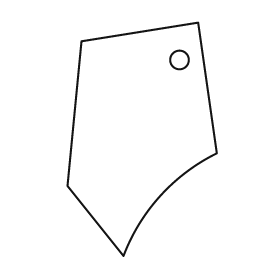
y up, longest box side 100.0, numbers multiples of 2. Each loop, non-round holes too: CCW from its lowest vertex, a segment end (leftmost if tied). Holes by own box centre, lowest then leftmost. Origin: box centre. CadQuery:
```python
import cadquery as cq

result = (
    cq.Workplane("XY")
    .moveTo(-8.0, -50.0)
    .threePointArc((8.0, -24.0), (32.0, -6.0))
    .lineTo(24.0, 50.0)
    .lineTo(-26.0, 42.0)
    .lineTo(-32.0, -20.0)
    .close()
    .moveTo(16.0, 34.0)
    .circle(4.0)
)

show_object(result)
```